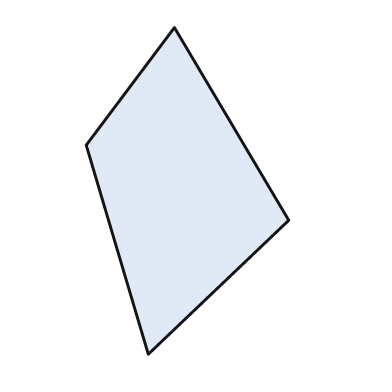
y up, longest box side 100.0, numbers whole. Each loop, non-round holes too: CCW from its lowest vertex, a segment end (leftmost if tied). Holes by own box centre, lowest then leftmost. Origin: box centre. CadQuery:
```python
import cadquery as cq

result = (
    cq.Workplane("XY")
    .moveTo(-12.0, -50.0)
    .lineTo(31.0, -9.0)
    .lineTo(-4.0, 50.0)
    .lineTo(-31.0, 14.0)
    .close()
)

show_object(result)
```